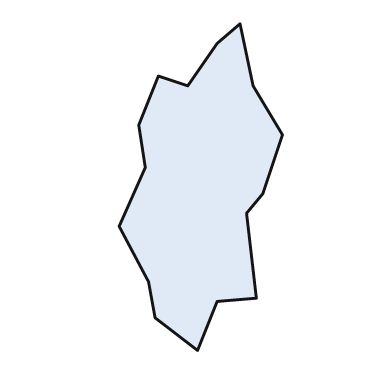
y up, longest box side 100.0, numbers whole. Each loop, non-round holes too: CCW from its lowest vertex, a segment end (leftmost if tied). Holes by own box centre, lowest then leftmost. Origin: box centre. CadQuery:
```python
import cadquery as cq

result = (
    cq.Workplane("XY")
    .moveTo(-1.0, -50.0)
    .lineTo(5.0, -35.0)
    .lineTo(17.0, -34.0)
    .lineTo(14.0, -8.0)
    .lineTo(19.0, -2.0)
    .lineTo(25.0, 16.0)
    .lineTo(16.0, 31.0)
    .lineTo(12.0, 50.0)
    .lineTo(5.0, 44.0)
    .lineTo(-4.0, 31.0)
    .lineTo(-13.0, 34.0)
    .lineTo(-19.0, 19.0)
    .lineTo(-17.0, 6.0)
    .lineTo(-25.0, -12.0)
    .lineTo(-16.0, -29.0)
    .lineTo(-14.0, -40.0)
    .close()
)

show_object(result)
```